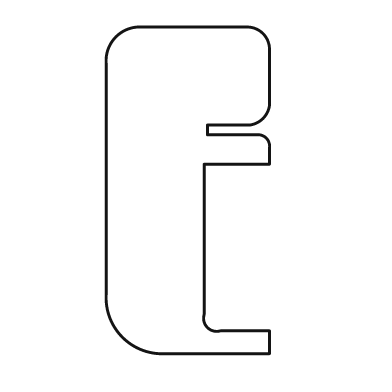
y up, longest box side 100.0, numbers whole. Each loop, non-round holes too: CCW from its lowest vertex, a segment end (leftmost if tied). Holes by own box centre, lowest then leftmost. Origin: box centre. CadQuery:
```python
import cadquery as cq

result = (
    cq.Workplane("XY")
    .moveTo(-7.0, -50.0)
    .lineTo(25.0, -50.0)
    .lineTo(25.0, -43.0)
    .lineTo(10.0, -43.0)
    .threePointArc((6.0, -42.0), (5.0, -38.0))
    .lineTo(5.0, 8.0)
    .lineTo(25.0, 8.0)
    .lineTo(25.0, 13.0)
    .threePointArc((24.0, 16.0), (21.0, 17.0))
    .lineTo(6.0, 17.0)
    .lineTo(6.0, 20.0)
    .lineTo(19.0, 20.0)
    .threePointArc((23.0, 22.0), (25.0, 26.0))
    .lineTo(25.0, 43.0)
    .threePointArc((23.0, 48.0), (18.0, 50.0))
    .lineTo(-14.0, 50.0)
    .threePointArc((-22.0, 47.0), (-25.0, 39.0))
    .lineTo(-25.0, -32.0)
    .threePointArc((-20.0, -45.0), (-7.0, -50.0))
    .close()
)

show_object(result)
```